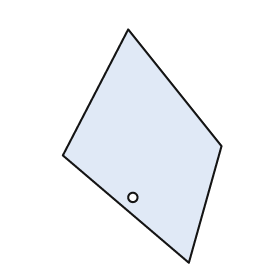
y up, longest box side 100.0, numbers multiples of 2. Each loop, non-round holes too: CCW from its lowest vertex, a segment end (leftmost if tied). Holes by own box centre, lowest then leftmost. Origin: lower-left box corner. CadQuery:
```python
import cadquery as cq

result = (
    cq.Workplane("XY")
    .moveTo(54.0, 0.0)
    .lineTo(68.0, 50.0)
    .lineTo(28.0, 100.0)
    .lineTo(0.0, 46.0)
    .close()
    .moveTo(30.0, 28.0)
    .circle(2.0)
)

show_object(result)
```